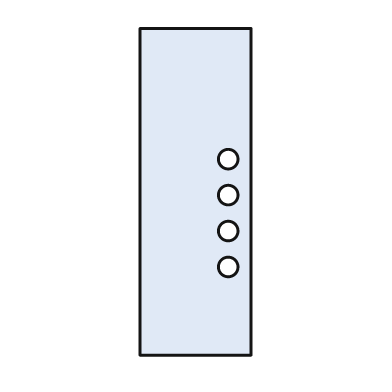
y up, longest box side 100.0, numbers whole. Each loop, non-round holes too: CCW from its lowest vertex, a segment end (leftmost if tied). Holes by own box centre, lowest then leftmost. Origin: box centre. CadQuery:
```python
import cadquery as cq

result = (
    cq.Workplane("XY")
    .moveTo(-17.0, -50.0)
    .lineTo(17.0, -50.0)
    .lineTo(17.0, 50.0)
    .lineTo(-17.0, 50.0)
    .close()
    .moveTo(10.0, -23.0)
    .circle(3.0)
    .moveTo(10.0, -12.0)
    .circle(3.0)
    .moveTo(10.0, -1.0)
    .circle(3.0)
    .moveTo(10.0, 10.0)
    .circle(3.0)
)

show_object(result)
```